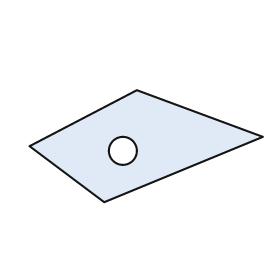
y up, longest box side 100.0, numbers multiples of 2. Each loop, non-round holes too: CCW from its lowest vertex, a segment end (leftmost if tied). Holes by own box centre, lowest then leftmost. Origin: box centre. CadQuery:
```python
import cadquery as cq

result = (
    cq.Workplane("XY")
    .moveTo(-18.0, -24.0)
    .lineTo(50.0, 4.0)
    .lineTo(-4.0, 24.0)
    .lineTo(-50.0, 0.0)
    .close()
    .moveTo(-10.0, -2.0)
    .circle(6.0)
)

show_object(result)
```